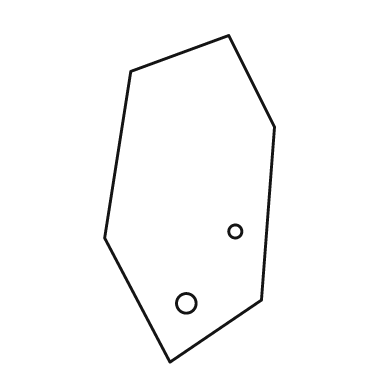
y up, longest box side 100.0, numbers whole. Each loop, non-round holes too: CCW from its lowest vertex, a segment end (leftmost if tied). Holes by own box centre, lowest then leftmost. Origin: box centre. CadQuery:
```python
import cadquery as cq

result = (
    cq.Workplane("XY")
    .moveTo(-6.0, -50.0)
    .lineTo(22.0, -31.0)
    .lineTo(26.0, 22.0)
    .lineTo(12.0, 50.0)
    .lineTo(-18.0, 39.0)
    .lineTo(-26.0, -12.0)
    .close()
    .moveTo(-1.0, -32.0)
    .circle(3.0)
    .moveTo(14.0, -10.0)
    .circle(2.0)
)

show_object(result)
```